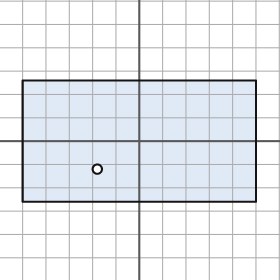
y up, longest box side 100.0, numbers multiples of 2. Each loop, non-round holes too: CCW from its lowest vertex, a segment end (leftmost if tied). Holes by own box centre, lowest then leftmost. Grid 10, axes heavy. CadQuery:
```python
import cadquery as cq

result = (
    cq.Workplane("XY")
    .moveTo(-50.0, -26.0)
    .lineTo(50.0, -26.0)
    .lineTo(50.0, 26.0)
    .lineTo(-50.0, 26.0)
    .close()
    .moveTo(-18.0, -12.0)
    .circle(2.0)
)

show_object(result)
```